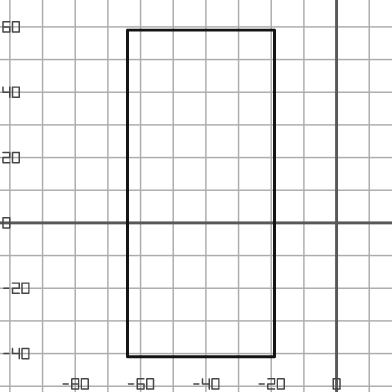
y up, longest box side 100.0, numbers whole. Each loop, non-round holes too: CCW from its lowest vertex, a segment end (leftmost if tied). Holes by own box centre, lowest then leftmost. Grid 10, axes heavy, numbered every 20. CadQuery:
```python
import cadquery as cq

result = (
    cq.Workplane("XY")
    .moveTo(-64.0, -41.0)
    .lineTo(-19.0, -41.0)
    .lineTo(-19.0, 59.0)
    .lineTo(-64.0, 59.0)
    .close()
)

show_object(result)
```